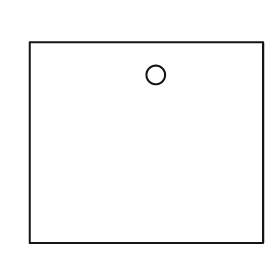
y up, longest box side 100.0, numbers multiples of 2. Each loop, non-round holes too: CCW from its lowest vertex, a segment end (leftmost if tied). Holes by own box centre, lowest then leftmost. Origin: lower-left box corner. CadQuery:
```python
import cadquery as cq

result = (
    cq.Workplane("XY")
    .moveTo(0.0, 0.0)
    .lineTo(100.0, 0.0)
    .lineTo(100.0, 86.0)
    .lineTo(0.0, 86.0)
    .close()
    .moveTo(54.0, 72.0)
    .circle(4.0)
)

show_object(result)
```